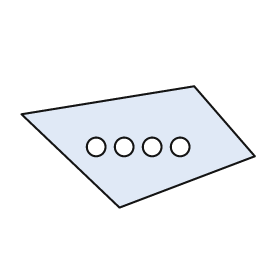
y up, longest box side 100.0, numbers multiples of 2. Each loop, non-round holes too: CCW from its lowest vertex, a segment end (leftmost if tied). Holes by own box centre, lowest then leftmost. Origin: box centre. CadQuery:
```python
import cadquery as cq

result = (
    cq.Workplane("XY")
    .moveTo(-8.0, -26.0)
    .lineTo(50.0, -4.0)
    .lineTo(24.0, 26.0)
    .lineTo(-50.0, 14.0)
    .close()
    .moveTo(-18.0, 0.0)
    .circle(4.0)
    .moveTo(-6.0, 0.0)
    .circle(4.0)
    .moveTo(6.0, 0.0)
    .circle(4.0)
    .moveTo(18.0, 0.0)
    .circle(4.0)
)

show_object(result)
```